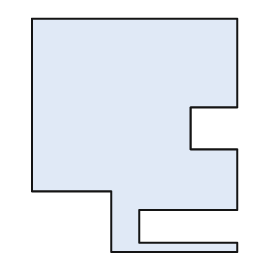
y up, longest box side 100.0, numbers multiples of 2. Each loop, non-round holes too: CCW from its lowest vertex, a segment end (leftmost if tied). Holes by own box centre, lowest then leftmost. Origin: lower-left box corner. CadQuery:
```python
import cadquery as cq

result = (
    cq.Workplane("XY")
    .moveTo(34.0, 0.0)
    .lineTo(88.0, 0.0)
    .lineTo(88.0, 4.0)
    .lineTo(46.0, 4.0)
    .lineTo(46.0, 18.0)
    .lineTo(88.0, 18.0)
    .lineTo(88.0, 44.0)
    .lineTo(68.0, 44.0)
    .lineTo(68.0, 62.0)
    .lineTo(88.0, 62.0)
    .lineTo(88.0, 100.0)
    .lineTo(0.0, 100.0)
    .lineTo(0.0, 26.0)
    .lineTo(34.0, 26.0)
    .close()
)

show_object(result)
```